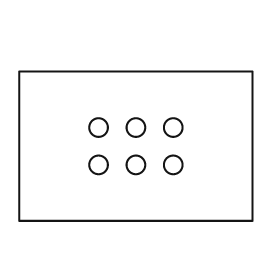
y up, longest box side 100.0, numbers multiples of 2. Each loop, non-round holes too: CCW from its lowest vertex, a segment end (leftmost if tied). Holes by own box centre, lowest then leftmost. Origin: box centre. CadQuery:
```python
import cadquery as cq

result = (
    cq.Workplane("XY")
    .moveTo(-50.0, -32.0)
    .lineTo(50.0, -32.0)
    .lineTo(50.0, 32.0)
    .lineTo(-50.0, 32.0)
    .close()
    .moveTo(-16.0, -8.0)
    .circle(4.0)
    .moveTo(0.0, -8.0)
    .circle(4.0)
    .moveTo(16.0, -8.0)
    .circle(4.0)
    .moveTo(-16.0, 8.0)
    .circle(4.0)
    .moveTo(0.0, 8.0)
    .circle(4.0)
    .moveTo(16.0, 8.0)
    .circle(4.0)
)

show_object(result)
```